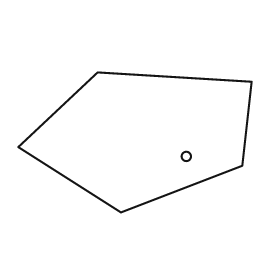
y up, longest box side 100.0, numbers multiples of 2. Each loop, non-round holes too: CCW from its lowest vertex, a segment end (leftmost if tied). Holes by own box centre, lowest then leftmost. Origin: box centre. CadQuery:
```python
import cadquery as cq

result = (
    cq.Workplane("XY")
    .moveTo(-6.0, -30.0)
    .lineTo(46.0, -10.0)
    .lineTo(50.0, 26.0)
    .lineTo(-16.0, 30.0)
    .lineTo(-50.0, -2.0)
    .close()
    .moveTo(22.0, -6.0)
    .circle(2.0)
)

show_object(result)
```